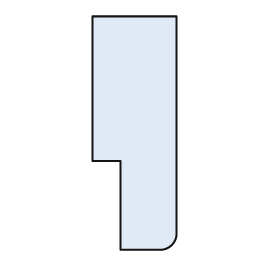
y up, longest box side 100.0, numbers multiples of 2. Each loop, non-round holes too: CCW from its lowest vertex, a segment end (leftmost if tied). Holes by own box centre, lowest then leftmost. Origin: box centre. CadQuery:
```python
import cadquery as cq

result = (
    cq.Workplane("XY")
    .moveTo(-6.0, -50.0)
    .lineTo(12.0, -50.0)
    .threePointArc((16.0, -48.0), (18.0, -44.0))
    .lineTo(18.0, 50.0)
    .lineTo(-18.0, 50.0)
    .lineTo(-18.0, -12.0)
    .lineTo(-6.0, -12.0)
    .close()
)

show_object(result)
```